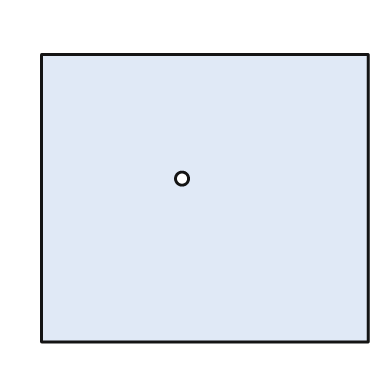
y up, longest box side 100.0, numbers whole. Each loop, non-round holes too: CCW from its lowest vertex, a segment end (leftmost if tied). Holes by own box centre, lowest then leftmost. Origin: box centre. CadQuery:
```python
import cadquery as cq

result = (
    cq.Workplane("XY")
    .moveTo(-50.0, -44.0)
    .lineTo(50.0, -44.0)
    .lineTo(50.0, 44.0)
    .lineTo(-50.0, 44.0)
    .close()
    .moveTo(-7.0, 6.0)
    .circle(2.0)
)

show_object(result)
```